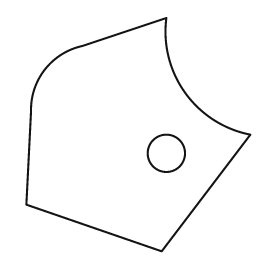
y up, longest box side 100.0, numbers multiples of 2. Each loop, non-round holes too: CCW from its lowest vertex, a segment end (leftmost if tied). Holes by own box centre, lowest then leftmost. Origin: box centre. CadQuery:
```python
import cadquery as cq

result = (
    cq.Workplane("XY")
    .moveTo(10.0, -50.0)
    .lineTo(48.0, 0.0)
    .threePointArc((20.0, 18.0), (12.0, 50.0))
    .lineTo(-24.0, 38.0)
    .threePointArc((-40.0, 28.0), (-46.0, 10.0))
    .lineTo(-48.0, -30.0)
    .close()
    .moveTo(12.0, -8.0)
    .circle(8.0)
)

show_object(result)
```